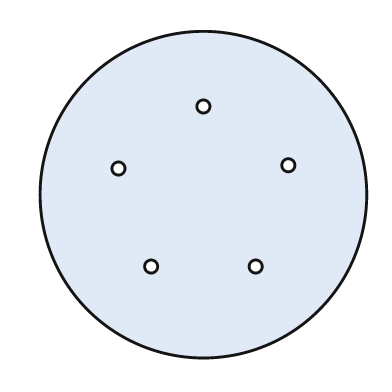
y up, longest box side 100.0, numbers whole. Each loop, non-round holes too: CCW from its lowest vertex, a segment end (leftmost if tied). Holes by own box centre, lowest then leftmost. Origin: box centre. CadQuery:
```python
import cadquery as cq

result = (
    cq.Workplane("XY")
    .moveTo(0.0, 0.0)
    .circle(50.0)
    .moveTo(-16.0, -22.0)
    .circle(2.0)
    .moveTo(16.0, -22.0)
    .circle(2.0)
    .moveTo(-26.0, 8.0)
    .circle(2.0)
    .moveTo(26.0, 9.0)
    .circle(2.0)
    .moveTo(0.0, 27.0)
    .circle(2.0)
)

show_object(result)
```